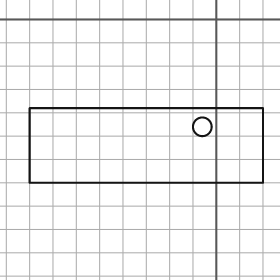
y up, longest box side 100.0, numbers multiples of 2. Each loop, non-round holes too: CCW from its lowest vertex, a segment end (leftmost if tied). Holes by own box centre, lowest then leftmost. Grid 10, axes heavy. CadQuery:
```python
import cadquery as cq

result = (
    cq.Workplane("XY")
    .moveTo(-80.0, -70.0)
    .lineTo(20.0, -70.0)
    .lineTo(20.0, -38.0)
    .lineTo(-80.0, -38.0)
    .close()
    .moveTo(-6.0, -46.0)
    .circle(4.0)
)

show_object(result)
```